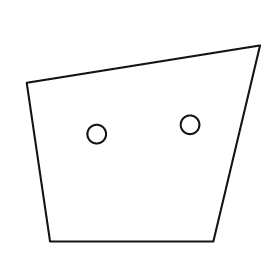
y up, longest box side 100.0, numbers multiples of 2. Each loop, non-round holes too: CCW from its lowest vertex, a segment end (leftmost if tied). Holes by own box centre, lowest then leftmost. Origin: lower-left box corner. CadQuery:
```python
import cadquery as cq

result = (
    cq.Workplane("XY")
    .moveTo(10.0, 0.0)
    .lineTo(80.0, 0.0)
    .lineTo(100.0, 84.0)
    .lineTo(0.0, 68.0)
    .close()
    .moveTo(30.0, 46.0)
    .circle(4.0)
    .moveTo(70.0, 50.0)
    .circle(4.0)
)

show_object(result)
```